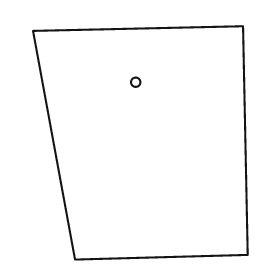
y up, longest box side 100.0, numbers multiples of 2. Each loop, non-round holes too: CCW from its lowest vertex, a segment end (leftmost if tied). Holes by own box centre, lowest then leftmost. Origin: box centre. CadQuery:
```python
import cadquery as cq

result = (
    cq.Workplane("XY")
    .moveTo(-28.0, -50.0)
    .lineTo(46.0, -48.0)
    .lineTo(44.0, 50.0)
    .lineTo(-46.0, 48.0)
    .close()
    .moveTo(-2.0, 26.0)
    .circle(2.0)
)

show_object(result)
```